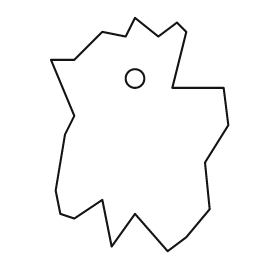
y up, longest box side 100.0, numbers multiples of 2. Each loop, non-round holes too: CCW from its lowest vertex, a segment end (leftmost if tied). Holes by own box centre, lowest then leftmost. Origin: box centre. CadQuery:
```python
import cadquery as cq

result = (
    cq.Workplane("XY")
    .moveTo(12.0, -50.0)
    .lineTo(20.0, -44.0)
    .lineTo(30.0, -32.0)
    .lineTo(28.0, -12.0)
    .lineTo(38.0, 4.0)
    .lineTo(36.0, 20.0)
    .lineTo(14.0, 20.0)
    .lineTo(20.0, 44.0)
    .lineTo(16.0, 48.0)
    .lineTo(8.0, 42.0)
    .lineTo(-2.0, 50.0)
    .lineTo(-6.0, 42.0)
    .lineTo(-16.0, 44.0)
    .lineTo(-28.0, 32.0)
    .lineTo(-38.0, 32.0)
    .lineTo(-28.0, 8.0)
    .lineTo(-32.0, 0.0)
    .lineTo(-36.0, -24.0)
    .lineTo(-34.0, -34.0)
    .lineTo(-28.0, -36.0)
    .lineTo(-16.0, -28.0)
    .lineTo(-12.0, -48.0)
    .lineTo(-2.0, -34.0)
    .close()
    .moveTo(-2.0, 24.0)
    .circle(4.0)
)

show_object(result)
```